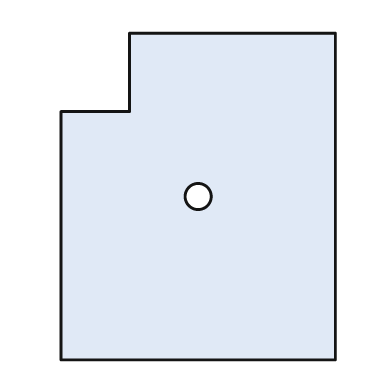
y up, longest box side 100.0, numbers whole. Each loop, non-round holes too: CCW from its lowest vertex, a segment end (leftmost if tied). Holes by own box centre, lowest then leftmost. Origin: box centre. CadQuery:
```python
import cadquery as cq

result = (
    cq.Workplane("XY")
    .moveTo(-42.0, -50.0)
    .lineTo(42.0, -50.0)
    .lineTo(42.0, 50.0)
    .lineTo(-21.0, 50.0)
    .lineTo(-21.0, 26.0)
    .lineTo(-42.0, 26.0)
    .close()
    .moveTo(0.0, 0.0)
    .circle(4.0)
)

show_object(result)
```